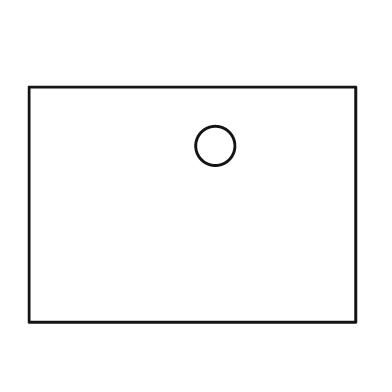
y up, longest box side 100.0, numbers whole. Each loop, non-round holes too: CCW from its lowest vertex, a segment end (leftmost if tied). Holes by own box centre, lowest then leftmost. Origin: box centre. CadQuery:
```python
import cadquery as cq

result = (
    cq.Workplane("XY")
    .moveTo(-50.0, -36.0)
    .lineTo(50.0, -36.0)
    .lineTo(50.0, 36.0)
    .lineTo(-50.0, 36.0)
    .close()
    .moveTo(7.0, 18.0)
    .circle(6.0)
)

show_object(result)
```